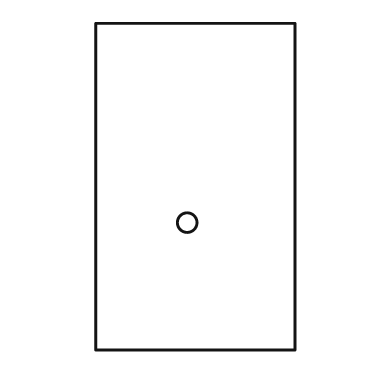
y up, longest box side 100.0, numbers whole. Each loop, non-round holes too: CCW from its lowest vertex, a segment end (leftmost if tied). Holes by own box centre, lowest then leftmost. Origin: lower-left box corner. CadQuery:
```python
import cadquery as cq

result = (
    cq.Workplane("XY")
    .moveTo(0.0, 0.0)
    .lineTo(61.0, 0.0)
    .lineTo(61.0, 100.0)
    .lineTo(0.0, 100.0)
    .close()
    .moveTo(28.0, 39.0)
    .circle(3.0)
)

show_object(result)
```